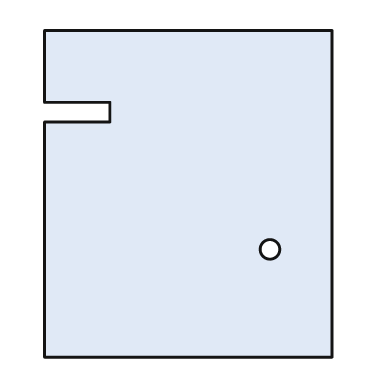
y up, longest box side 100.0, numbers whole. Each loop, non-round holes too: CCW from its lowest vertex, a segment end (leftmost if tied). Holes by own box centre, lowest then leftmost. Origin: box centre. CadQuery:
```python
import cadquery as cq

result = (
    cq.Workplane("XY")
    .moveTo(-44.0, -50.0)
    .lineTo(44.0, -50.0)
    .lineTo(44.0, 50.0)
    .lineTo(-44.0, 50.0)
    .lineTo(-44.0, 28.0)
    .lineTo(-24.0, 28.0)
    .lineTo(-24.0, 22.0)
    .lineTo(-44.0, 22.0)
    .close()
    .moveTo(25.0, -17.0)
    .circle(3.0)
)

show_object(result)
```